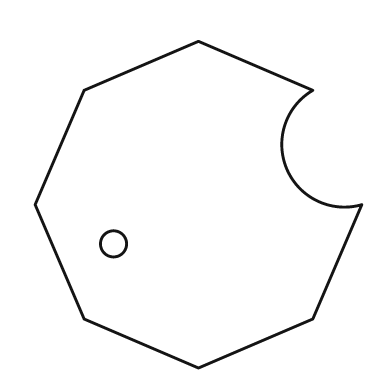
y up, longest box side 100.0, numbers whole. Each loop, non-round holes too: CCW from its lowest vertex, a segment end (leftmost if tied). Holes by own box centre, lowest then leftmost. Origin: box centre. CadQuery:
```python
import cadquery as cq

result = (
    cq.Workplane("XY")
    .moveTo(0.0, -50.0)
    .lineTo(35.0, -35.0)
    .lineTo(50.0, 0.0)
    .threePointArc((27.0, 11.0), (35.0, 35.0))
    .lineTo(0.0, 50.0)
    .lineTo(-35.0, 35.0)
    .lineTo(-50.0, 0.0)
    .lineTo(-35.0, -35.0)
    .close()
    .moveTo(-26.0, -12.0)
    .circle(4.0)
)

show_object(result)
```